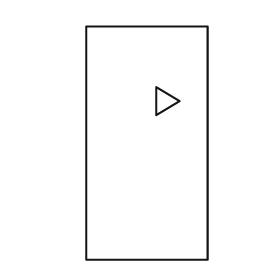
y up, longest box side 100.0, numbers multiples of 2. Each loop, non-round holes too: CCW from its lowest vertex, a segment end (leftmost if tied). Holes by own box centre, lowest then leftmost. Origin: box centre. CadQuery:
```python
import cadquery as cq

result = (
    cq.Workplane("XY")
    .moveTo(-26.0, -50.0)
    .lineTo(26.0, -50.0)
    .lineTo(26.0, 50.0)
    .lineTo(-26.0, 50.0)
    .close()
    .moveTo(4.0, 12.0)
    .lineTo(14.0, 18.0)
    .lineTo(4.0, 24.0)
    .close()
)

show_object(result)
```